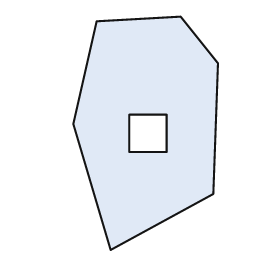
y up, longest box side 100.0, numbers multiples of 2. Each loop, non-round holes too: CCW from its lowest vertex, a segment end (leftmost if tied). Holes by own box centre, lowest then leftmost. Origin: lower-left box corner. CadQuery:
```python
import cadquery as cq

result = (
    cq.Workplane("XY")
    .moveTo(16.0, 0.0)
    .lineTo(60.0, 24.0)
    .lineTo(62.0, 80.0)
    .lineTo(46.0, 100.0)
    .lineTo(10.0, 98.0)
    .lineTo(0.0, 54.0)
    .close()
    .moveTo(24.0, 42.0)
    .lineTo(40.0, 42.0)
    .lineTo(40.0, 58.0)
    .lineTo(24.0, 58.0)
    .close()
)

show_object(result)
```